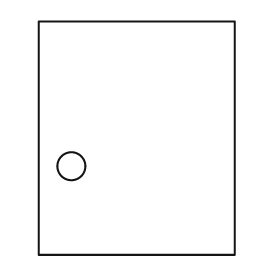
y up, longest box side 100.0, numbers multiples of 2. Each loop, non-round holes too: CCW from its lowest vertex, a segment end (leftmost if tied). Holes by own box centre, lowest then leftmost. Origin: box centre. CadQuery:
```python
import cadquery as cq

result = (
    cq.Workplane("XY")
    .moveTo(-42.0, -50.0)
    .lineTo(42.0, -50.0)
    .lineTo(42.0, 50.0)
    .lineTo(-42.0, 50.0)
    .close()
    .moveTo(-28.0, -12.0)
    .circle(6.0)
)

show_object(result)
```